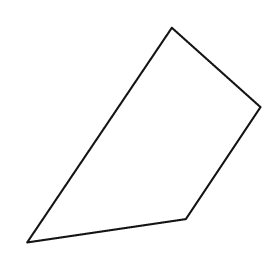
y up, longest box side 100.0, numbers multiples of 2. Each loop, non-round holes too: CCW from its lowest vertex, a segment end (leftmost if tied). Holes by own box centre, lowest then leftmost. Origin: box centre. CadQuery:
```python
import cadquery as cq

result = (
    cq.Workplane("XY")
    .moveTo(-50.0, -46.0)
    .lineTo(18.0, -36.0)
    .lineTo(50.0, 12.0)
    .lineTo(12.0, 46.0)
    .close()
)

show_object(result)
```